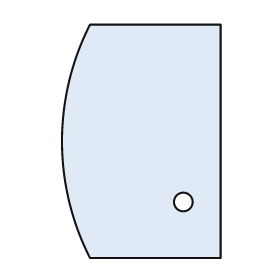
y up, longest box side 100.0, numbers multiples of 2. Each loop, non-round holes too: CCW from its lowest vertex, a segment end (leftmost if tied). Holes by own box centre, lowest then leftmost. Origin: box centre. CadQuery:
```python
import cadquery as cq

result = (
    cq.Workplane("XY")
    .moveTo(-22.0, -50.0)
    .lineTo(34.0, -50.0)
    .lineTo(34.0, 50.0)
    .lineTo(-22.0, 50.0)
    .threePointArc((-34.0, 0.0), (-22.0, -50.0))
    .close()
    .moveTo(18.0, -26.0)
    .circle(4.0)
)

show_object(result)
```